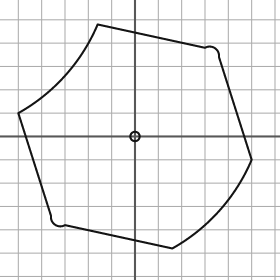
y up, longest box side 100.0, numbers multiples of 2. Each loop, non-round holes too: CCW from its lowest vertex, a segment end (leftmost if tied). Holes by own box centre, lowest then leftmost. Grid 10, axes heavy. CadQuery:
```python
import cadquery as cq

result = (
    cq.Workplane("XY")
    .moveTo(16.0, -48.0)
    .threePointArc((36.0, -32.0), (50.0, -10.0))
    .lineTo(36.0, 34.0)
    .threePointArc((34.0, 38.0), (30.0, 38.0))
    .lineTo(-16.0, 48.0)
    .threePointArc((-30.0, 26.0), (-50.0, 10.0))
    .lineTo(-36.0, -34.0)
    .threePointArc((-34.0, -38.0), (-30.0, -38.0))
    .close()
    .moveTo(0.0, 0.0)
    .circle(2.0)
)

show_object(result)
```